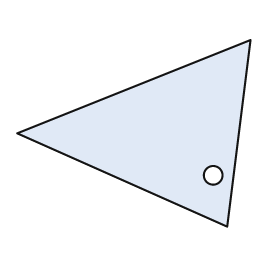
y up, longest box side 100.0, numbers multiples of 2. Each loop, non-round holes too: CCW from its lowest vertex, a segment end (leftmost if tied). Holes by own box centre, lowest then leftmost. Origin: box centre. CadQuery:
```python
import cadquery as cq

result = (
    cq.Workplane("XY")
    .moveTo(40.0, -40.0)
    .lineTo(50.0, 40.0)
    .lineTo(-50.0, 0.0)
    .close()
    .moveTo(34.0, -18.0)
    .circle(4.0)
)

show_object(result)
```